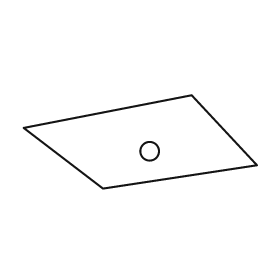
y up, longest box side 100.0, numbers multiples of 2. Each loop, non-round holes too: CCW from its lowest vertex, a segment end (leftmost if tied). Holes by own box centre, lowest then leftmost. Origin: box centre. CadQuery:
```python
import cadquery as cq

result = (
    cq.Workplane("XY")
    .moveTo(-16.0, -20.0)
    .lineTo(50.0, -10.0)
    .lineTo(22.0, 20.0)
    .lineTo(-50.0, 6.0)
    .close()
    .moveTo(4.0, -4.0)
    .circle(4.0)
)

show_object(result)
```